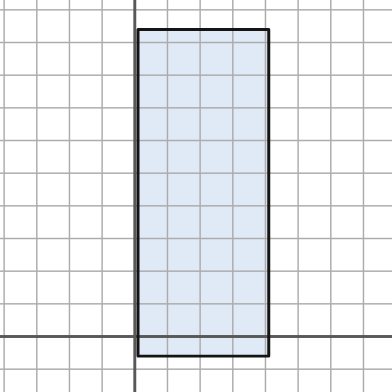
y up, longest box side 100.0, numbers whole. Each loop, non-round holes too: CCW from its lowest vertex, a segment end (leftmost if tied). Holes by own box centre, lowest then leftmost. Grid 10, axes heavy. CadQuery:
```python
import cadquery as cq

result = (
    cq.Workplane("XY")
    .moveTo(1.0, -6.0)
    .lineTo(41.0, -6.0)
    .lineTo(41.0, 94.0)
    .lineTo(1.0, 94.0)
    .close()
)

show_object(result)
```